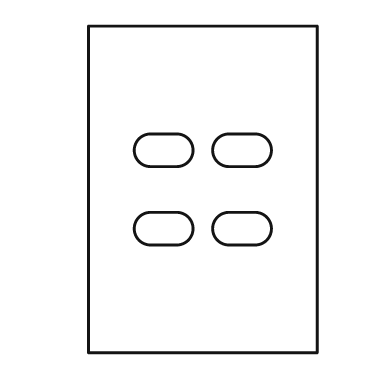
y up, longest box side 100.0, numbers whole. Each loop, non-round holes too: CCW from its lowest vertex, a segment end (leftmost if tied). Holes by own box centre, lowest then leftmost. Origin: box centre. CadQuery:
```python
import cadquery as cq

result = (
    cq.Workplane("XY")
    .moveTo(-35.0, -50.0)
    .lineTo(35.0, -50.0)
    .lineTo(35.0, 50.0)
    .lineTo(-35.0, 50.0)
    .close()
    .moveTo(-16.0, -17.0)
    .lineTo(-8.0, -17.0)
    .threePointArc((-3.0, -12.0), (-8.0, -7.0))
    .lineTo(-16.0, -7.0)
    .threePointArc((-21.0, -12.0), (-16.0, -17.0))
    .close()
    .moveTo(8.0, -17.0)
    .lineTo(16.0, -17.0)
    .threePointArc((21.0, -12.0), (16.0, -7.0))
    .lineTo(8.0, -7.0)
    .threePointArc((3.0, -12.0), (8.0, -17.0))
    .close()
    .moveTo(-16.0, 7.0)
    .lineTo(-8.0, 7.0)
    .threePointArc((-3.0, 12.0), (-8.0, 17.0))
    .lineTo(-16.0, 17.0)
    .threePointArc((-21.0, 12.0), (-16.0, 7.0))
    .close()
    .moveTo(8.0, 7.0)
    .lineTo(16.0, 7.0)
    .threePointArc((21.0, 12.0), (16.0, 17.0))
    .lineTo(8.0, 17.0)
    .threePointArc((3.0, 12.0), (8.0, 7.0))
    .close()
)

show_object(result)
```